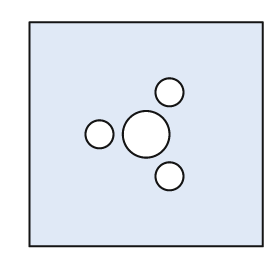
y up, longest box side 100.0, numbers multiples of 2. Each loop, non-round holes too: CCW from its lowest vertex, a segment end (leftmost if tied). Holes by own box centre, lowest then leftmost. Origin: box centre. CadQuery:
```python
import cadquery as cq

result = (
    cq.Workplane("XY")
    .moveTo(-50.0, -48.0)
    .lineTo(50.0, -48.0)
    .lineTo(50.0, 48.0)
    .lineTo(-50.0, 48.0)
    .close()
    .moveTo(10.0, -18.0)
    .circle(6.0)
    .moveTo(-20.0, 0.0)
    .circle(6.0)
    .moveTo(0.0, 0.0)
    .circle(10.0)
    .moveTo(10.0, 18.0)
    .circle(6.0)
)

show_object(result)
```